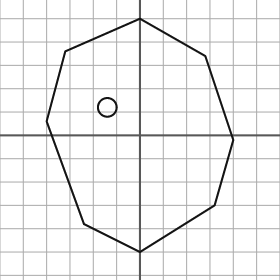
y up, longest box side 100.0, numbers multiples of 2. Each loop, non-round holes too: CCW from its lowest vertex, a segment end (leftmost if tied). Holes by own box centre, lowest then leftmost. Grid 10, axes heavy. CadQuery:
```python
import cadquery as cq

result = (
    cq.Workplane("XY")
    .moveTo(0.0, -50.0)
    .lineTo(32.0, -30.0)
    .lineTo(40.0, -2.0)
    .lineTo(28.0, 34.0)
    .lineTo(0.0, 50.0)
    .lineTo(-32.0, 36.0)
    .lineTo(-40.0, 6.0)
    .lineTo(-24.0, -38.0)
    .close()
    .moveTo(-14.0, 12.0)
    .circle(4.0)
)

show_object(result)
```